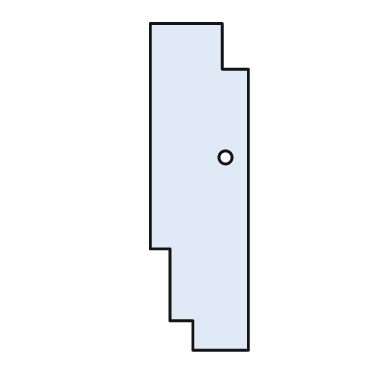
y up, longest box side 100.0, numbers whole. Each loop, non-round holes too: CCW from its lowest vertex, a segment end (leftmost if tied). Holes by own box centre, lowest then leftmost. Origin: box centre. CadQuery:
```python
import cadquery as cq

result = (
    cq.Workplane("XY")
    .moveTo(-2.0, -50.0)
    .lineTo(15.0, -50.0)
    .lineTo(15.0, 36.0)
    .lineTo(7.0, 36.0)
    .lineTo(7.0, 50.0)
    .lineTo(-15.0, 50.0)
    .lineTo(-15.0, -19.0)
    .lineTo(-9.0, -19.0)
    .lineTo(-9.0, -41.0)
    .lineTo(-2.0, -41.0)
    .close()
    .moveTo(8.0, 9.0)
    .circle(2.0)
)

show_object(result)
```